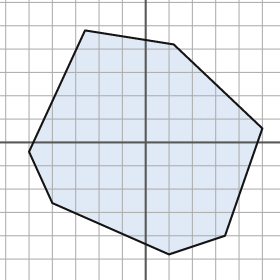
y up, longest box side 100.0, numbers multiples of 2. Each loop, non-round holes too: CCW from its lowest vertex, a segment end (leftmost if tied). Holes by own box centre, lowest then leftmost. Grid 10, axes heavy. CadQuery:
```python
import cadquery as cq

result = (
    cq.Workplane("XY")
    .moveTo(10.0, -48.0)
    .lineTo(34.0, -40.0)
    .lineTo(50.0, 6.0)
    .lineTo(12.0, 42.0)
    .lineTo(-26.0, 48.0)
    .lineTo(-50.0, -4.0)
    .lineTo(-40.0, -26.0)
    .close()
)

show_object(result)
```